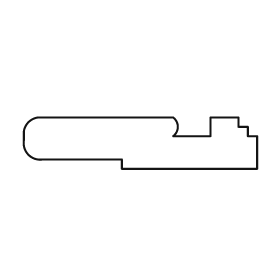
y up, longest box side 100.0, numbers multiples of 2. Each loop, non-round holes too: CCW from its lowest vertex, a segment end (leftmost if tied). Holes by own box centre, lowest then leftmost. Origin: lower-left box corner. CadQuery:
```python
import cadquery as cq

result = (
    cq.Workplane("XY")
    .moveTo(42.0, 0.0)
    .lineTo(100.0, 0.0)
    .lineTo(100.0, 14.0)
    .lineTo(96.0, 14.0)
    .lineTo(96.0, 18.0)
    .lineTo(92.0, 18.0)
    .lineTo(92.0, 22.0)
    .lineTo(80.0, 22.0)
    .lineTo(80.0, 14.0)
    .lineTo(64.0, 14.0)
    .threePointArc((66.0, 18.0), (64.0, 22.0))
    .lineTo(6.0, 22.0)
    .threePointArc((2.0, 20.0), (0.0, 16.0))
    .lineTo(0.0, 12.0)
    .threePointArc((2.0, 6.0), (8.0, 4.0))
    .lineTo(42.0, 4.0)
    .close()
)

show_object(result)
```